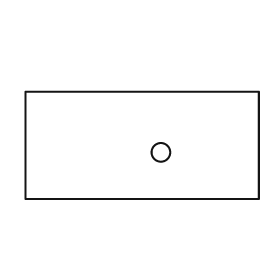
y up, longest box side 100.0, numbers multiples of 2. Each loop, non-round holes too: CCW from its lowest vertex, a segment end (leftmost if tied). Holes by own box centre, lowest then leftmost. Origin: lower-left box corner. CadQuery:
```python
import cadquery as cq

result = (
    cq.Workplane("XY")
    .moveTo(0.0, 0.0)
    .lineTo(100.0, 0.0)
    .lineTo(100.0, 46.0)
    .lineTo(0.0, 46.0)
    .close()
    .moveTo(58.0, 20.0)
    .circle(4.0)
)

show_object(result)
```